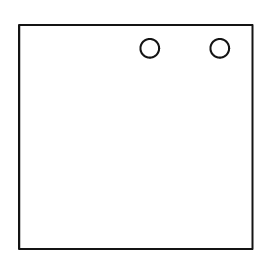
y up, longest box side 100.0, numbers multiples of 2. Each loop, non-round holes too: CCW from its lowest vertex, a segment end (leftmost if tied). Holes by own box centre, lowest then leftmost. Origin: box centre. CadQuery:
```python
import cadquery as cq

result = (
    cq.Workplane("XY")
    .moveTo(-50.0, -48.0)
    .lineTo(50.0, -48.0)
    .lineTo(50.0, 48.0)
    .lineTo(-50.0, 48.0)
    .close()
    .moveTo(6.0, 38.0)
    .circle(4.0)
    .moveTo(36.0, 38.0)
    .circle(4.0)
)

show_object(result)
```